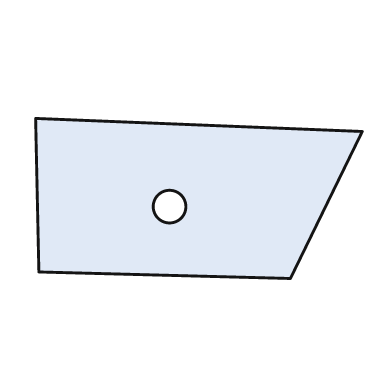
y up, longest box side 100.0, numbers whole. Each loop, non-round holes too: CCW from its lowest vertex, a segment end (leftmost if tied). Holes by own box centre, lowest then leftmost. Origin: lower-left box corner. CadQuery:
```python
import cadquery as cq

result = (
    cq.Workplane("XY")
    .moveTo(78.0, 0.0)
    .lineTo(100.0, 45.0)
    .lineTo(0.0, 49.0)
    .lineTo(1.0, 2.0)
    .close()
    .moveTo(41.0, 22.0)
    .circle(5.0)
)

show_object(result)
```